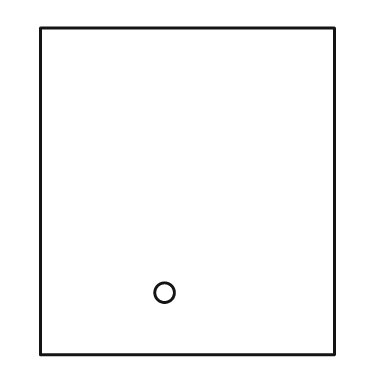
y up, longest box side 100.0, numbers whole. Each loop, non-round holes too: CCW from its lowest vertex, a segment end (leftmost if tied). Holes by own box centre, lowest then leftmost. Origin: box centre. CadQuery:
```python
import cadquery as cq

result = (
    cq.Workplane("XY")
    .moveTo(-45.0, -50.0)
    .lineTo(45.0, -50.0)
    .lineTo(45.0, 50.0)
    .lineTo(-45.0, 50.0)
    .close()
    .moveTo(-7.0, -31.0)
    .circle(3.0)
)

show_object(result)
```